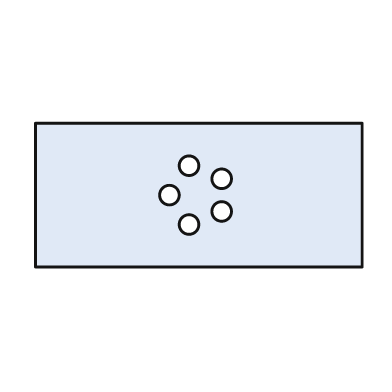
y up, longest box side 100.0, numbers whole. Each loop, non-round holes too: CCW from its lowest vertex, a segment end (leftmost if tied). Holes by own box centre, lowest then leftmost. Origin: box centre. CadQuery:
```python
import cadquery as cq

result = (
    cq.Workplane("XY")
    .moveTo(-50.0, -22.0)
    .lineTo(50.0, -22.0)
    .lineTo(50.0, 22.0)
    .lineTo(-50.0, 22.0)
    .close()
    .moveTo(-3.0, -9.0)
    .circle(3.0)
    .moveTo(7.0, -5.0)
    .circle(3.0)
    .moveTo(-9.0, 0.0)
    .circle(3.0)
    .moveTo(7.0, 5.0)
    .circle(3.0)
    .moveTo(-3.0, 9.0)
    .circle(3.0)
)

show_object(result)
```